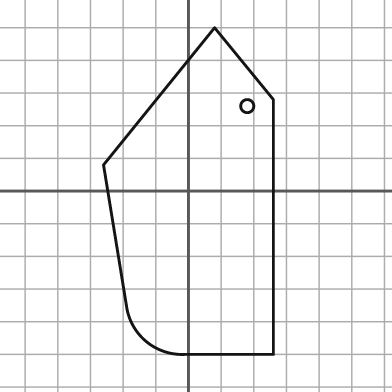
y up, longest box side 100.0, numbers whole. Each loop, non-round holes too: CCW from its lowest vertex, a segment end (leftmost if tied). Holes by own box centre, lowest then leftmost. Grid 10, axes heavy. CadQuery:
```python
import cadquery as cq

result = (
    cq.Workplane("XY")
    .moveTo(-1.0, -50.0)
    .lineTo(26.0, -50.0)
    .lineTo(26.0, 28.0)
    .lineTo(8.0, 50.0)
    .lineTo(-26.0, 8.0)
    .lineTo(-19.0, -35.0)
    .threePointArc((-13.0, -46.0), (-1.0, -50.0))
    .close()
    .moveTo(18.0, 26.0)
    .circle(2.0)
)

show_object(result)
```